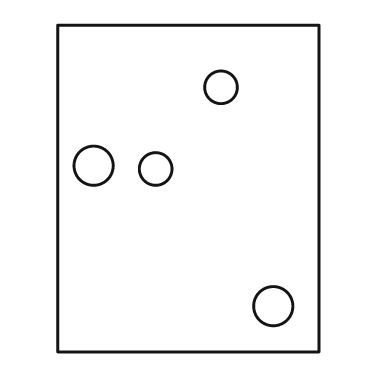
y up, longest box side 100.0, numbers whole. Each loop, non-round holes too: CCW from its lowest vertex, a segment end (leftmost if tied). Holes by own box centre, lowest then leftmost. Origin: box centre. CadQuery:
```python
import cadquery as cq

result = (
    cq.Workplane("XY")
    .moveTo(-40.0, -50.0)
    .lineTo(40.0, -50.0)
    .lineTo(40.0, 50.0)
    .lineTo(-40.0, 50.0)
    .close()
    .moveTo(26.0, -36.0)
    .circle(6.0)
    .moveTo(-10.0, 6.0)
    .circle(5.0)
    .moveTo(-29.0, 7.0)
    .circle(6.0)
    .moveTo(10.0, 31.0)
    .circle(5.0)
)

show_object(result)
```